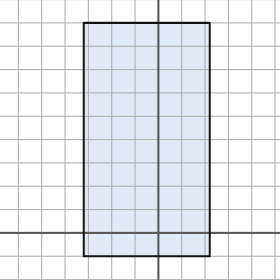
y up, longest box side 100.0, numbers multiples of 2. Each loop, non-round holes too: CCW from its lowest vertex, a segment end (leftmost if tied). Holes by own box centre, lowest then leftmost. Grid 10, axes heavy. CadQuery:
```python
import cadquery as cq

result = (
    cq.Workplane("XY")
    .moveTo(-32.0, -10.0)
    .lineTo(22.0, -10.0)
    .lineTo(22.0, 90.0)
    .lineTo(-32.0, 90.0)
    .close()
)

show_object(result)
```